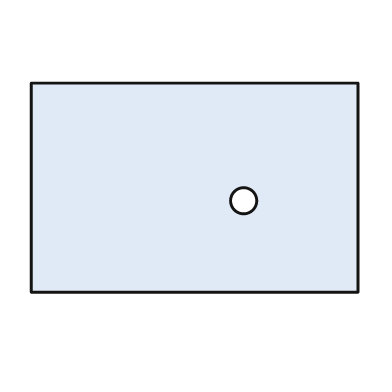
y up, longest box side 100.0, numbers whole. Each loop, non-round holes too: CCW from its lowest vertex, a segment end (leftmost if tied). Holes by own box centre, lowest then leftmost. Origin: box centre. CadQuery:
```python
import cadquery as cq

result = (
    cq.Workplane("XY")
    .moveTo(-50.0, -32.0)
    .lineTo(50.0, -32.0)
    .lineTo(50.0, 32.0)
    .lineTo(-50.0, 32.0)
    .close()
    .moveTo(15.0, -4.0)
    .circle(4.0)
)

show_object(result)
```